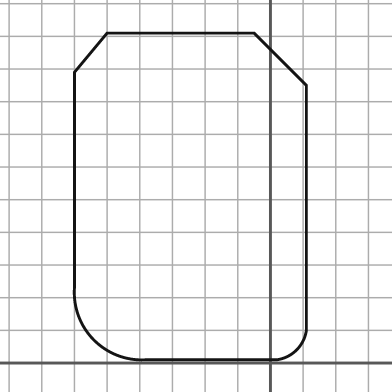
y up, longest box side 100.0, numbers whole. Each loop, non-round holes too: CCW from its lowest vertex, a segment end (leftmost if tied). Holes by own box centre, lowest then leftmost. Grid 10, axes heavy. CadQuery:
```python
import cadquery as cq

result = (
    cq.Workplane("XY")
    .moveTo(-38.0, 1.0)
    .lineTo(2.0, 1.0)
    .threePointArc((8.0, 4.0), (11.0, 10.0))
    .lineTo(11.0, 85.0)
    .lineTo(-5.0, 101.0)
    .lineTo(-50.0, 101.0)
    .lineTo(-60.0, 89.0)
    .lineTo(-60.0, 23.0)
    .threePointArc((-54.0, 7.0), (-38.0, 1.0))
    .close()
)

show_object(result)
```